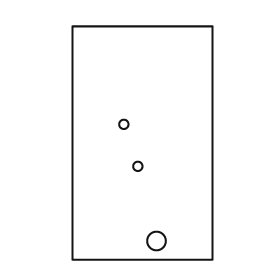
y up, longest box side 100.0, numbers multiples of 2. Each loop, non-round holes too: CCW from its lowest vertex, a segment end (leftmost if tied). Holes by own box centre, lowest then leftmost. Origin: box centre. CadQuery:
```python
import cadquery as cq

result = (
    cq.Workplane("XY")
    .moveTo(-30.0, -50.0)
    .lineTo(30.0, -50.0)
    .lineTo(30.0, 50.0)
    .lineTo(-30.0, 50.0)
    .close()
    .moveTo(6.0, -42.0)
    .circle(4.0)
    .moveTo(-2.0, -10.0)
    .circle(2.0)
    .moveTo(-8.0, 8.0)
    .circle(2.0)
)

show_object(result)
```